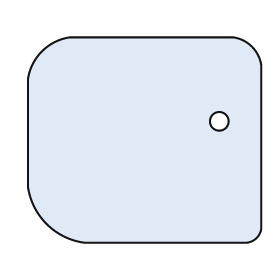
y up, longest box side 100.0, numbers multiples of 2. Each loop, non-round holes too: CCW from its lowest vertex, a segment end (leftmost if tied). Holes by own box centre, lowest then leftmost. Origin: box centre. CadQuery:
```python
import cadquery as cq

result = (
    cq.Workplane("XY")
    .moveTo(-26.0, -44.0)
    .lineTo(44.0, -44.0)
    .threePointArc((48.0, -42.0), (50.0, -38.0))
    .lineTo(50.0, 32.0)
    .threePointArc((46.0, 40.0), (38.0, 44.0))
    .lineTo(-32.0, 44.0)
    .threePointArc((-44.0, 38.0), (-50.0, 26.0))
    .lineTo(-50.0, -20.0)
    .threePointArc((-42.0, -36.0), (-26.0, -44.0))
    .close()
    .moveTo(32.0, 8.0)
    .circle(4.0)
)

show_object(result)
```